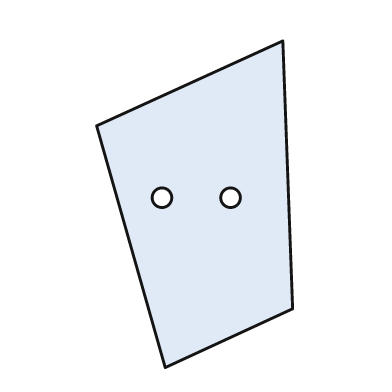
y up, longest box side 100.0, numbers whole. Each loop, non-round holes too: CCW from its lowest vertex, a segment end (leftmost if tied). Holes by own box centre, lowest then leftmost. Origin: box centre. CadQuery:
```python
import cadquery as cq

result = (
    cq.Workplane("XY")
    .moveTo(-9.0, -50.0)
    .lineTo(30.0, -32.0)
    .lineTo(27.0, 50.0)
    .lineTo(-30.0, 24.0)
    .close()
    .moveTo(-10.0, 2.0)
    .circle(3.0)
    .moveTo(11.0, 2.0)
    .circle(3.0)
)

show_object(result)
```